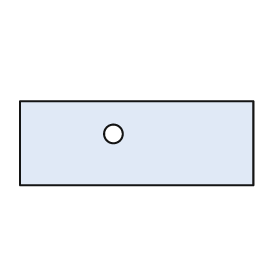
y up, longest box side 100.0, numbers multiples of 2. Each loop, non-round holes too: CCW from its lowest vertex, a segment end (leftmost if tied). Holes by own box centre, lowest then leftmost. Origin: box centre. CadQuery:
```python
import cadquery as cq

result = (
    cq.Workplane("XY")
    .moveTo(-50.0, -18.0)
    .lineTo(50.0, -18.0)
    .lineTo(50.0, 18.0)
    .lineTo(-50.0, 18.0)
    .close()
    .moveTo(-10.0, 4.0)
    .circle(4.0)
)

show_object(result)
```